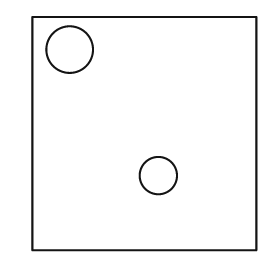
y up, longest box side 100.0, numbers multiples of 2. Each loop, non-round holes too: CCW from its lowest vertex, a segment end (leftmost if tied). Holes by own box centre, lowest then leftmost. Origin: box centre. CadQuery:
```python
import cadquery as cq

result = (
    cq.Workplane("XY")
    .moveTo(-48.0, -50.0)
    .lineTo(48.0, -50.0)
    .lineTo(48.0, 50.0)
    .lineTo(-48.0, 50.0)
    .close()
    .moveTo(6.0, -18.0)
    .circle(8.0)
    .moveTo(-32.0, 36.0)
    .circle(10.0)
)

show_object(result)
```